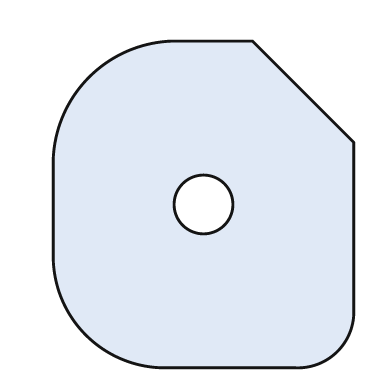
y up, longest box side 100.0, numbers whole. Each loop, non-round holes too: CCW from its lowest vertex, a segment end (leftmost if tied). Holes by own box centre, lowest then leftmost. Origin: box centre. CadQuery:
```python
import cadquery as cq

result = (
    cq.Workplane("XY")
    .moveTo(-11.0, -50.0)
    .lineTo(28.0, -50.0)
    .threePointArc((41.0, -45.0), (46.0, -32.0))
    .lineTo(46.0, 19.0)
    .lineTo(15.0, 50.0)
    .lineTo(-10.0, 50.0)
    .threePointArc((-35.0, 39.0), (-46.0, 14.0))
    .lineTo(-46.0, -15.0)
    .threePointArc((-36.0, -40.0), (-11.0, -50.0))
    .close()
    .moveTo(0.0, 0.0)
    .circle(9.0)
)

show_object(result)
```